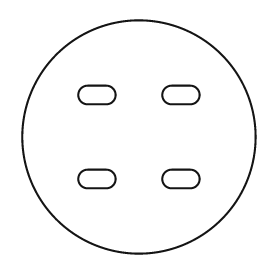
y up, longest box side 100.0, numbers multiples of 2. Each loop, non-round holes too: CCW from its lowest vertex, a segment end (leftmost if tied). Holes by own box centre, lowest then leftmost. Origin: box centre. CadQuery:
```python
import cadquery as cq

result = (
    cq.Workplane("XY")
    .moveTo(0.0, 0.0)
    .circle(50.0)
    .moveTo(-22.0, -22.0)
    .lineTo(-14.0, -22.0)
    .threePointArc((-10.0, -18.0), (-14.0, -14.0))
    .lineTo(-22.0, -14.0)
    .threePointArc((-26.0, -18.0), (-22.0, -22.0))
    .close()
    .moveTo(14.0, -22.0)
    .lineTo(22.0, -22.0)
    .threePointArc((26.0, -18.0), (22.0, -14.0))
    .lineTo(14.0, -14.0)
    .threePointArc((10.0, -18.0), (14.0, -22.0))
    .close()
    .moveTo(-22.0, 14.0)
    .lineTo(-14.0, 14.0)
    .threePointArc((-10.0, 18.0), (-14.0, 22.0))
    .lineTo(-22.0, 22.0)
    .threePointArc((-26.0, 18.0), (-22.0, 14.0))
    .close()
    .moveTo(14.0, 14.0)
    .lineTo(22.0, 14.0)
    .threePointArc((26.0, 18.0), (22.0, 22.0))
    .lineTo(14.0, 22.0)
    .threePointArc((10.0, 18.0), (14.0, 14.0))
    .close()
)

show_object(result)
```